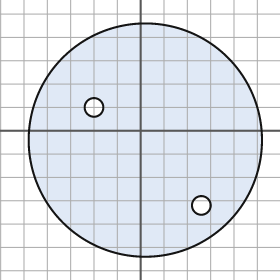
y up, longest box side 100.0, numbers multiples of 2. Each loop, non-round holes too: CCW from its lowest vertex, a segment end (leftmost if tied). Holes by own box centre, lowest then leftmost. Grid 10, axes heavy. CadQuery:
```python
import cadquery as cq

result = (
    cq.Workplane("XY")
    .moveTo(2.0, -4.0)
    .circle(50.0)
    .moveTo(26.0, -32.0)
    .circle(4.0)
    .moveTo(-20.0, 10.0)
    .circle(4.0)
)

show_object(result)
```